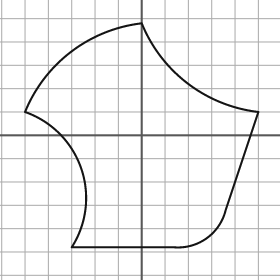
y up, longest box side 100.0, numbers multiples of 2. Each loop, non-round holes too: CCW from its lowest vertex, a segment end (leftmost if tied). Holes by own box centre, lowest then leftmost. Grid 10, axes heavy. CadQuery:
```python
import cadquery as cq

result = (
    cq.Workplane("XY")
    .moveTo(-30.0, -48.0)
    .lineTo(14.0, -48.0)
    .threePointArc((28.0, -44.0), (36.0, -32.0))
    .lineTo(50.0, 10.0)
    .threePointArc((20.0, 22.0), (0.0, 48.0))
    .threePointArc((-30.0, 36.0), (-50.0, 10.0))
    .threePointArc((-26.0, -14.0), (-30.0, -48.0))
    .close()
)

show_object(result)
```